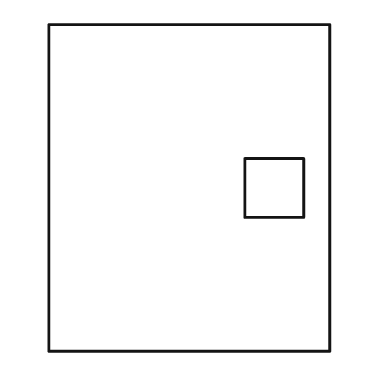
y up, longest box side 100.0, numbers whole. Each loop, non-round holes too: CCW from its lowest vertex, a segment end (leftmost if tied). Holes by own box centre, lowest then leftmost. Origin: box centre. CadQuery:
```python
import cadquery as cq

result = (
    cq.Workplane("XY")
    .moveTo(-43.0, -50.0)
    .lineTo(43.0, -50.0)
    .lineTo(43.0, 50.0)
    .lineTo(-43.0, 50.0)
    .close()
    .moveTo(17.0, -9.0)
    .lineTo(35.0, -9.0)
    .lineTo(35.0, 9.0)
    .lineTo(17.0, 9.0)
    .close()
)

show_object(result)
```